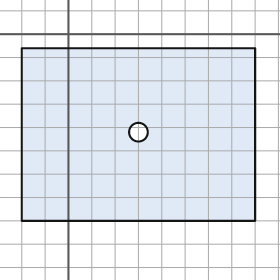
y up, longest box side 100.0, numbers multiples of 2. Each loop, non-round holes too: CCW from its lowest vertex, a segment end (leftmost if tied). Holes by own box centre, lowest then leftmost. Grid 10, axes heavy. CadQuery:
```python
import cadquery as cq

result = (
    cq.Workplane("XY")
    .moveTo(-20.0, -80.0)
    .lineTo(80.0, -80.0)
    .lineTo(80.0, -6.0)
    .lineTo(-20.0, -6.0)
    .close()
    .moveTo(30.0, -42.0)
    .circle(4.0)
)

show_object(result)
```